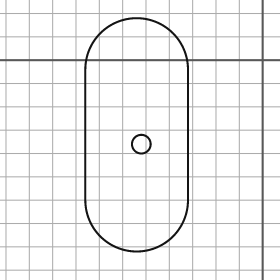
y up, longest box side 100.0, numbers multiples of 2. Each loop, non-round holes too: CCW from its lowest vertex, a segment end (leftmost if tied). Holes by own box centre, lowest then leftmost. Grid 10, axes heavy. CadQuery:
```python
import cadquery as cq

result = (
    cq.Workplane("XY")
    .moveTo(-76.0, -60.0)
    .threePointArc((-54.0, -82.0), (-32.0, -60.0))
    .lineTo(-32.0, -4.0)
    .threePointArc((-54.0, 18.0), (-76.0, -4.0))
    .close()
    .moveTo(-52.0, -36.0)
    .circle(4.0)
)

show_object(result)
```